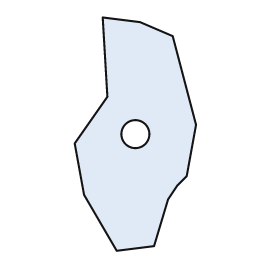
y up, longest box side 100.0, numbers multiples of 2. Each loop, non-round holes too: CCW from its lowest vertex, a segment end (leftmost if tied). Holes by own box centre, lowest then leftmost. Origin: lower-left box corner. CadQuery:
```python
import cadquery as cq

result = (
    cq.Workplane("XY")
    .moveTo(18.0, 0.0)
    .lineTo(34.0, 2.0)
    .lineTo(40.0, 22.0)
    .lineTo(44.0, 28.0)
    .lineTo(48.0, 32.0)
    .lineTo(52.0, 54.0)
    .lineTo(42.0, 92.0)
    .lineTo(28.0, 98.0)
    .lineTo(12.0, 100.0)
    .lineTo(14.0, 66.0)
    .lineTo(0.0, 46.0)
    .lineTo(4.0, 24.0)
    .close()
    .moveTo(26.0, 50.0)
    .circle(6.0)
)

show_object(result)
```